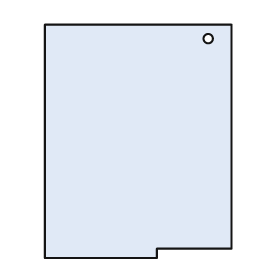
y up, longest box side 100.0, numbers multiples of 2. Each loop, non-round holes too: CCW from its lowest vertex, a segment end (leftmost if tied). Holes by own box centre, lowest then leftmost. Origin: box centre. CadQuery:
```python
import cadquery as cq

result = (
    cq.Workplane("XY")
    .moveTo(-40.0, -50.0)
    .lineTo(8.0, -50.0)
    .lineTo(8.0, -46.0)
    .lineTo(40.0, -46.0)
    .lineTo(40.0, 50.0)
    .lineTo(-40.0, 50.0)
    .close()
    .moveTo(30.0, 44.0)
    .circle(2.0)
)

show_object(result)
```